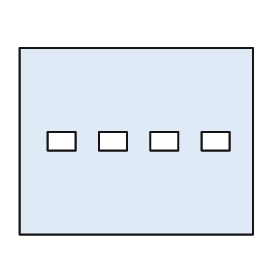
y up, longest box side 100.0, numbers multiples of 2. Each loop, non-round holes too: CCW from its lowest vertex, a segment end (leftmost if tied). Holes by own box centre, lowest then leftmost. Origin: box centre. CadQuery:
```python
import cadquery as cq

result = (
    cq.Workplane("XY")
    .moveTo(-50.0, -40.0)
    .lineTo(50.0, -40.0)
    .lineTo(50.0, 40.0)
    .lineTo(-50.0, 40.0)
    .close()
    .moveTo(-38.0, -4.0)
    .lineTo(-26.0, -4.0)
    .lineTo(-26.0, 4.0)
    .lineTo(-38.0, 4.0)
    .close()
    .moveTo(-16.0, -4.0)
    .lineTo(-4.0, -4.0)
    .lineTo(-4.0, 4.0)
    .lineTo(-16.0, 4.0)
    .close()
    .moveTo(6.0, -4.0)
    .lineTo(18.0, -4.0)
    .lineTo(18.0, 4.0)
    .lineTo(6.0, 4.0)
    .close()
    .moveTo(28.0, -4.0)
    .lineTo(40.0, -4.0)
    .lineTo(40.0, 4.0)
    .lineTo(28.0, 4.0)
    .close()
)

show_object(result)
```